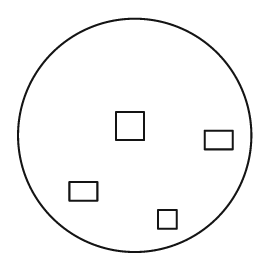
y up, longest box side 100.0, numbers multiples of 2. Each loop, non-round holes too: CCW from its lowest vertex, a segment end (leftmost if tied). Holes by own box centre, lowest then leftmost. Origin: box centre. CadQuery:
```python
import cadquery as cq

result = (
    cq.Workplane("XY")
    .moveTo(0.0, 0.0)
    .circle(50.0)
    .moveTo(10.0, -40.0)
    .lineTo(18.0, -40.0)
    .lineTo(18.0, -32.0)
    .lineTo(10.0, -32.0)
    .close()
    .moveTo(-28.0, -28.0)
    .lineTo(-16.0, -28.0)
    .lineTo(-16.0, -20.0)
    .lineTo(-28.0, -20.0)
    .close()
    .moveTo(30.0, -6.0)
    .lineTo(42.0, -6.0)
    .lineTo(42.0, 2.0)
    .lineTo(30.0, 2.0)
    .close()
    .moveTo(-8.0, -2.0)
    .lineTo(4.0, -2.0)
    .lineTo(4.0, 10.0)
    .lineTo(-8.0, 10.0)
    .close()
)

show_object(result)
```